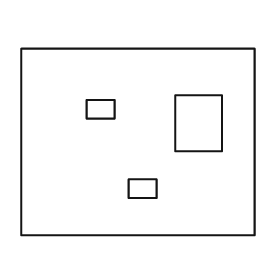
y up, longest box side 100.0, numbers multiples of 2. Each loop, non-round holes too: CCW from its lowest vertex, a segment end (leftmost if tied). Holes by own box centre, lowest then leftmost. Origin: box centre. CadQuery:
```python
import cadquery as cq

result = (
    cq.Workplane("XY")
    .moveTo(-50.0, -40.0)
    .lineTo(50.0, -40.0)
    .lineTo(50.0, 40.0)
    .lineTo(-50.0, 40.0)
    .close()
    .moveTo(-4.0, -24.0)
    .lineTo(8.0, -24.0)
    .lineTo(8.0, -16.0)
    .lineTo(-4.0, -16.0)
    .close()
    .moveTo(16.0, -4.0)
    .lineTo(36.0, -4.0)
    .lineTo(36.0, 20.0)
    .lineTo(16.0, 20.0)
    .close()
    .moveTo(-22.0, 10.0)
    .lineTo(-10.0, 10.0)
    .lineTo(-10.0, 18.0)
    .lineTo(-22.0, 18.0)
    .close()
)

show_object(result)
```